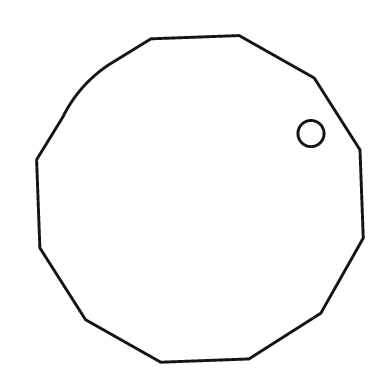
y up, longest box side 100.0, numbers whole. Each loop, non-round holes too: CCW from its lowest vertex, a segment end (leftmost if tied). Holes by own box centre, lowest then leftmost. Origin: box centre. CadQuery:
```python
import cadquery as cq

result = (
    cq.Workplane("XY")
    .moveTo(-12.0, -50.0)
    .lineTo(15.0, -49.0)
    .lineTo(37.0, -35.0)
    .lineTo(50.0, -12.0)
    .lineTo(49.0, 15.0)
    .lineTo(35.0, 37.0)
    .lineTo(12.0, 50.0)
    .lineTo(-15.0, 49.0)
    .lineTo(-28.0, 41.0)
    .threePointArc((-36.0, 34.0), (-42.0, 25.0))
    .lineTo(-50.0, 12.0)
    .lineTo(-49.0, -15.0)
    .lineTo(-35.0, -37.0)
    .close()
    .moveTo(34.0, 20.0)
    .circle(4.0)
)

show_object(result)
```